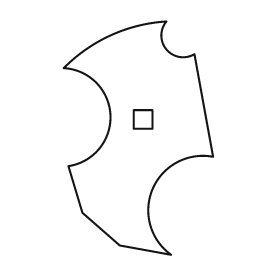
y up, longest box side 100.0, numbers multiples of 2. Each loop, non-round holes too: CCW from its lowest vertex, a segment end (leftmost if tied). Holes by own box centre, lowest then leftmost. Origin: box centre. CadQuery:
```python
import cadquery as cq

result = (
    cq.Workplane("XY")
    .moveTo(14.0, -50.0)
    .threePointArc((6.0, -22.0), (32.0, -8.0))
    .lineTo(24.0, 36.0)
    .threePointArc((12.0, 38.0), (12.0, 50.0))
    .threePointArc((-12.0, 44.0), (-32.0, 30.0))
    .threePointArc((-12.0, 10.0), (-30.0, -12.0))
    .lineTo(-24.0, -32.0)
    .lineTo(-8.0, -46.0)
    .close()
    .moveTo(-2.0, 4.0)
    .lineTo(6.0, 4.0)
    .lineTo(6.0, 12.0)
    .lineTo(-2.0, 12.0)
    .close()
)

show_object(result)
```